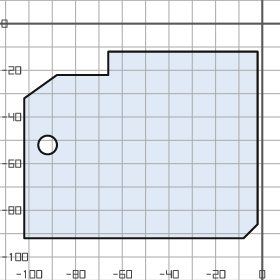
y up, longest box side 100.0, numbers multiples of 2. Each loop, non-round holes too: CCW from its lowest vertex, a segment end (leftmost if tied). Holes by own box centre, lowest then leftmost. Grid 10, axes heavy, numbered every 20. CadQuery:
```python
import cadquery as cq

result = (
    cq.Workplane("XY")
    .moveTo(-102.0, -92.0)
    .lineTo(-8.0, -92.0)
    .lineTo(-2.0, -86.0)
    .lineTo(-2.0, -12.0)
    .lineTo(-66.0, -12.0)
    .lineTo(-66.0, -22.0)
    .lineTo(-88.0, -22.0)
    .lineTo(-102.0, -32.0)
    .close()
    .moveTo(-92.0, -52.0)
    .circle(4.0)
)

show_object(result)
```